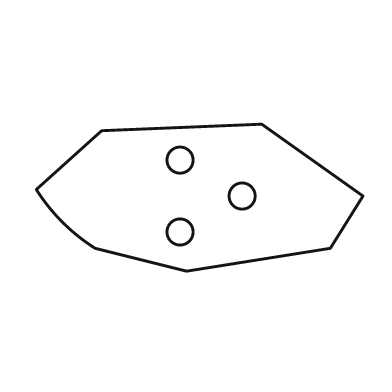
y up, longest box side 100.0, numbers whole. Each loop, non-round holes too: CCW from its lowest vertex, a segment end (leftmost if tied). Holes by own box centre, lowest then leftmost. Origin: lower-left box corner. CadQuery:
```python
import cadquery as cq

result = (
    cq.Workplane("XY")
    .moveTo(46.0, 0.0)
    .lineTo(90.0, 7.0)
    .lineTo(100.0, 23.0)
    .lineTo(69.0, 45.0)
    .lineTo(20.0, 43.0)
    .lineTo(0.0, 25.0)
    .threePointArc((8.0, 15.0), (18.0, 7.0))
    .close()
    .moveTo(44.0, 12.0)
    .circle(4.0)
    .moveTo(63.0, 23.0)
    .circle(4.0)
    .moveTo(44.0, 34.0)
    .circle(4.0)
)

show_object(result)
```